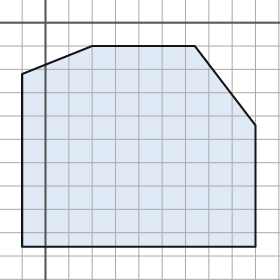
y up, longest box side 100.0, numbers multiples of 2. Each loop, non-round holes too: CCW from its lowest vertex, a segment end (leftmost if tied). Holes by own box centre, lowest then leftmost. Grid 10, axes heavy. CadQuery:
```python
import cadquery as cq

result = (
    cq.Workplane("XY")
    .moveTo(-10.0, -96.0)
    .lineTo(90.0, -96.0)
    .lineTo(90.0, -44.0)
    .lineTo(64.0, -10.0)
    .lineTo(20.0, -10.0)
    .lineTo(-10.0, -22.0)
    .close()
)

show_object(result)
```